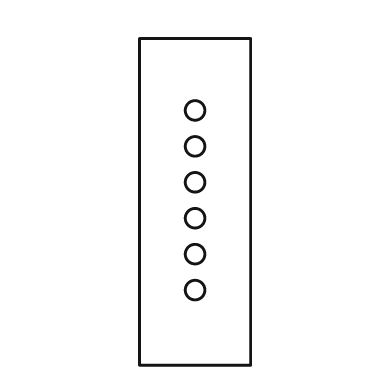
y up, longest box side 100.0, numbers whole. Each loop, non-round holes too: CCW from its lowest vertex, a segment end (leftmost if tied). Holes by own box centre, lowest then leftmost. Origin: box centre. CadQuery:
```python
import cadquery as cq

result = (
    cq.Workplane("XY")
    .moveTo(-17.0, -50.0)
    .lineTo(17.0, -50.0)
    .lineTo(17.0, 50.0)
    .lineTo(-17.0, 50.0)
    .close()
    .moveTo(0.0, -27.0)
    .circle(3.0)
    .moveTo(0.0, -16.0)
    .circle(3.0)
    .moveTo(0.0, -5.0)
    .circle(3.0)
    .moveTo(0.0, 6.0)
    .circle(3.0)
    .moveTo(0.0, 17.0)
    .circle(3.0)
    .moveTo(0.0, 28.0)
    .circle(3.0)
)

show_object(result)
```